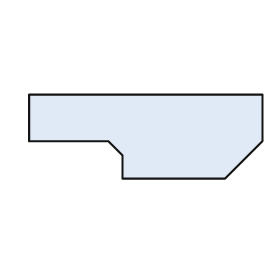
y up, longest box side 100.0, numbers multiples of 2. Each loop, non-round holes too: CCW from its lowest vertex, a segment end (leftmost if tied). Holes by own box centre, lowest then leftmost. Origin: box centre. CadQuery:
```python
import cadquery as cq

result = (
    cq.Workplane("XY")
    .moveTo(-10.0, -18.0)
    .lineTo(34.0, -18.0)
    .lineTo(50.0, -2.0)
    .lineTo(50.0, 18.0)
    .lineTo(-50.0, 18.0)
    .lineTo(-50.0, -2.0)
    .lineTo(-16.0, -2.0)
    .lineTo(-10.0, -8.0)
    .close()
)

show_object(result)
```